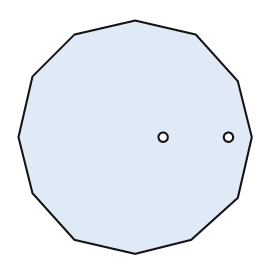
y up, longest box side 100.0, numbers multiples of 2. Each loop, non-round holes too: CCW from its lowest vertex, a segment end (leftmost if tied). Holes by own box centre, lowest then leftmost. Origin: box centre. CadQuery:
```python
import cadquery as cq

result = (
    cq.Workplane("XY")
    .moveTo(0.0, -50.0)
    .lineTo(24.0, -44.0)
    .lineTo(44.0, -26.0)
    .lineTo(50.0, 0.0)
    .lineTo(44.0, 24.0)
    .lineTo(26.0, 44.0)
    .lineTo(0.0, 50.0)
    .lineTo(-26.0, 44.0)
    .lineTo(-44.0, 26.0)
    .lineTo(-50.0, 0.0)
    .lineTo(-44.0, -24.0)
    .lineTo(-26.0, -44.0)
    .close()
    .moveTo(12.0, 0.0)
    .circle(2.0)
    .moveTo(40.0, 0.0)
    .circle(2.0)
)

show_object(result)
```